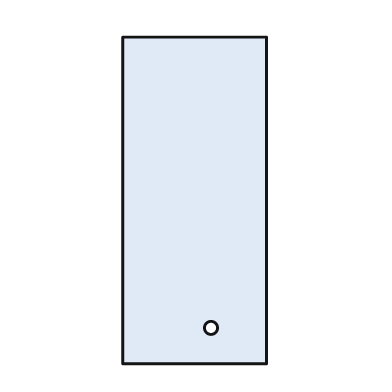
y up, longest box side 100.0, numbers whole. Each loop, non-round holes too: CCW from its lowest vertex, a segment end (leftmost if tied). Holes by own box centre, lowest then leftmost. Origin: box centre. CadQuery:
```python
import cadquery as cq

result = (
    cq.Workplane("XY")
    .moveTo(-22.0, -50.0)
    .lineTo(22.0, -50.0)
    .lineTo(22.0, 50.0)
    .lineTo(-22.0, 50.0)
    .close()
    .moveTo(5.0, -39.0)
    .circle(2.0)
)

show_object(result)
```